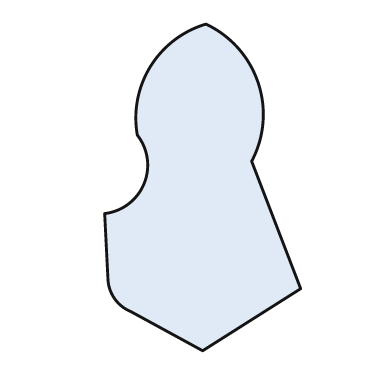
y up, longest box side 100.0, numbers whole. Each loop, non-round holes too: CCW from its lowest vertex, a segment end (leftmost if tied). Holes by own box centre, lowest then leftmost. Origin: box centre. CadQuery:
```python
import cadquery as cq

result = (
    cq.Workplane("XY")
    .moveTo(0.0, -50.0)
    .lineTo(30.0, -31.0)
    .lineTo(15.0, 8.0)
    .threePointArc((17.0, 32.0), (1.0, 50.0))
    .threePointArc((-16.0, 37.0), (-20.0, 16.0))
    .threePointArc((-18.0, 1.0), (-30.0, -8.0))
    .lineTo(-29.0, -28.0)
    .threePointArc((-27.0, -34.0), (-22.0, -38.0))
    .close()
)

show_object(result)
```